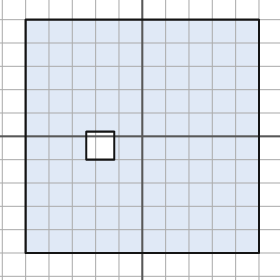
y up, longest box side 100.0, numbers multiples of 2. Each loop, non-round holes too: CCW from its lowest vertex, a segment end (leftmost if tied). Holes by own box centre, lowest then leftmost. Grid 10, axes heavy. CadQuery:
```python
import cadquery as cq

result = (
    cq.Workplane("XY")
    .moveTo(-50.0, -50.0)
    .lineTo(50.0, -50.0)
    .lineTo(50.0, 50.0)
    .lineTo(-50.0, 50.0)
    .close()
    .moveTo(-24.0, -10.0)
    .lineTo(-12.0, -10.0)
    .lineTo(-12.0, 2.0)
    .lineTo(-24.0, 2.0)
    .close()
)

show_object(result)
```